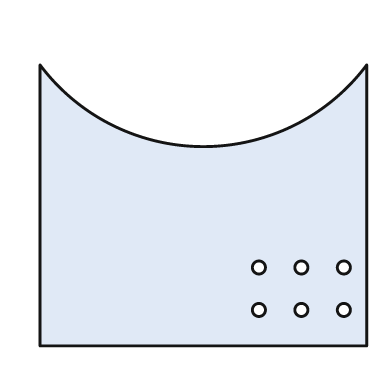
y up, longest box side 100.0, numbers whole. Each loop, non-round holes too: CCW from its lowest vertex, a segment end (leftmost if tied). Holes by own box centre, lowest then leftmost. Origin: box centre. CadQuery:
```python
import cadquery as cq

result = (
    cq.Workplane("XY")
    .moveTo(-50.0, -43.0)
    .lineTo(50.0, -43.0)
    .lineTo(50.0, 43.0)
    .threePointArc((0.0, 18.0), (-50.0, 43.0))
    .close()
    .moveTo(17.0, -32.0)
    .circle(2.0)
    .moveTo(30.0, -32.0)
    .circle(2.0)
    .moveTo(43.0, -32.0)
    .circle(2.0)
    .moveTo(17.0, -19.0)
    .circle(2.0)
    .moveTo(30.0, -19.0)
    .circle(2.0)
    .moveTo(43.0, -19.0)
    .circle(2.0)
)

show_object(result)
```